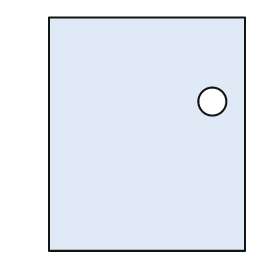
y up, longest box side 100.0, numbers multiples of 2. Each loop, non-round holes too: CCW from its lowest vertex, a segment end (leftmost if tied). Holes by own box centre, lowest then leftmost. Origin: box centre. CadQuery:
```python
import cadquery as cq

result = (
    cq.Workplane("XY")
    .moveTo(-42.0, -50.0)
    .lineTo(42.0, -50.0)
    .lineTo(42.0, 50.0)
    .lineTo(-42.0, 50.0)
    .close()
    .moveTo(28.0, 14.0)
    .circle(6.0)
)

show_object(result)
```